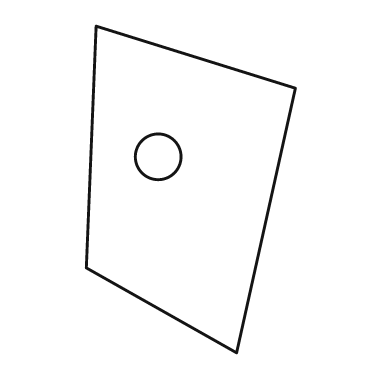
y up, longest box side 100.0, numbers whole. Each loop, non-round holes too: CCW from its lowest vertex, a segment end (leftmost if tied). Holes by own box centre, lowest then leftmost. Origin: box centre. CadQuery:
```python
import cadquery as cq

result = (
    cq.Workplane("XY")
    .moveTo(14.0, -50.0)
    .lineTo(32.0, 31.0)
    .lineTo(-29.0, 50.0)
    .lineTo(-32.0, -24.0)
    .close()
    .moveTo(-10.0, 10.0)
    .circle(7.0)
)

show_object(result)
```